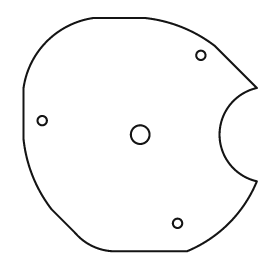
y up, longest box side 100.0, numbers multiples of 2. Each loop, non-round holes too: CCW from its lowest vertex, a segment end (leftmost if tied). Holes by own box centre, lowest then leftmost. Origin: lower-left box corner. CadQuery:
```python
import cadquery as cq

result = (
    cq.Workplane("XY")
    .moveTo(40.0, 0.0)
    .lineTo(70.0, 0.0)
    .threePointArc((88.0, 12.0), (100.0, 30.0))
    .threePointArc((84.0, 50.0), (100.0, 70.0))
    .lineTo(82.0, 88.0)
    .threePointArc((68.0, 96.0), (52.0, 100.0))
    .lineTo(30.0, 100.0)
    .threePointArc((10.0, 90.0), (0.0, 70.0))
    .lineTo(0.0, 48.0)
    .threePointArc((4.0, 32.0), (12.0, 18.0))
    .lineTo(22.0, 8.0)
    .threePointArc((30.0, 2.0), (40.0, 0.0))
    .close()
    .moveTo(66.0, 12.0)
    .circle(2.0)
    .moveTo(50.0, 50.0)
    .circle(4.0)
    .moveTo(8.0, 56.0)
    .circle(2.0)
    .moveTo(76.0, 84.0)
    .circle(2.0)
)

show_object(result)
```